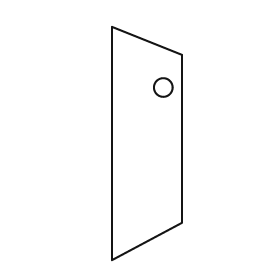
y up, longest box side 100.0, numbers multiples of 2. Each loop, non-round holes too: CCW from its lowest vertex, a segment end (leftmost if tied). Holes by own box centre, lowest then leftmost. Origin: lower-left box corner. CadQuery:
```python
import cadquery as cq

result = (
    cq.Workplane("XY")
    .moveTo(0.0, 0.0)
    .lineTo(30.0, 16.0)
    .lineTo(30.0, 88.0)
    .lineTo(0.0, 100.0)
    .close()
    .moveTo(22.0, 74.0)
    .circle(4.0)
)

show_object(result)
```